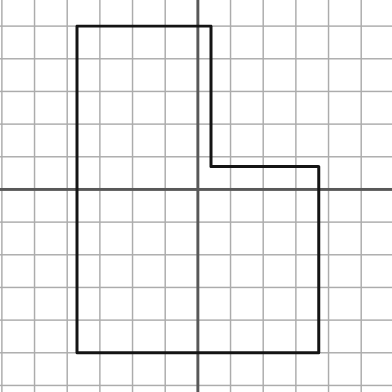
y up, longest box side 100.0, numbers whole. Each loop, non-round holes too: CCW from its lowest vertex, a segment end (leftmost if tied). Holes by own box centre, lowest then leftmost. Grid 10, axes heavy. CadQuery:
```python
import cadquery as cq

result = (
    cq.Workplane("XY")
    .moveTo(-37.0, -50.0)
    .lineTo(37.0, -50.0)
    .lineTo(37.0, 7.0)
    .lineTo(4.0, 7.0)
    .lineTo(4.0, 50.0)
    .lineTo(-37.0, 50.0)
    .close()
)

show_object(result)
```